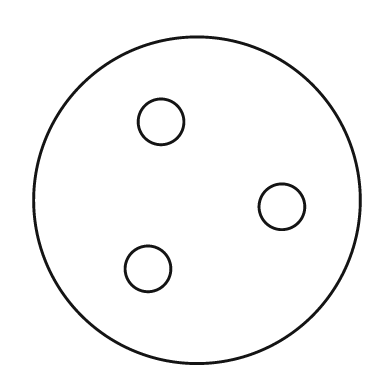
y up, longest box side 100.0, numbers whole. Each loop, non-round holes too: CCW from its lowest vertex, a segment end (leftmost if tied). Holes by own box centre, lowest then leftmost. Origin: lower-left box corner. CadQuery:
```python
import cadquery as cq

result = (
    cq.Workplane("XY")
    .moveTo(50.0, 50.0)
    .circle(50.0)
    .moveTo(35.0, 29.0)
    .circle(7.0)
    .moveTo(76.0, 48.0)
    .circle(7.0)
    .moveTo(39.0, 74.0)
    .circle(7.0)
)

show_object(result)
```